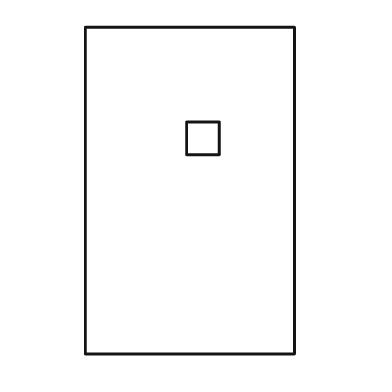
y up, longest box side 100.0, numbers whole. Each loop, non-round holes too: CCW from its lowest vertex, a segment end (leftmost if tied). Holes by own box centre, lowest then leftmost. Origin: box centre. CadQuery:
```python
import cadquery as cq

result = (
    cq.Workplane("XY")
    .moveTo(-32.0, -50.0)
    .lineTo(32.0, -50.0)
    .lineTo(32.0, 50.0)
    .lineTo(-32.0, 50.0)
    .close()
    .moveTo(-1.0, 11.0)
    .lineTo(9.0, 11.0)
    .lineTo(9.0, 21.0)
    .lineTo(-1.0, 21.0)
    .close()
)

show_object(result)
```